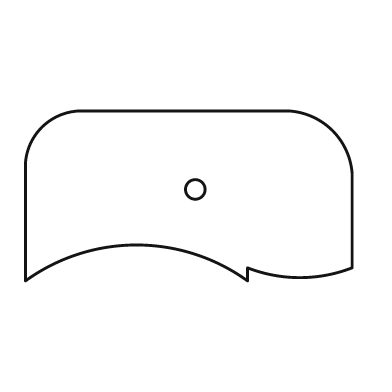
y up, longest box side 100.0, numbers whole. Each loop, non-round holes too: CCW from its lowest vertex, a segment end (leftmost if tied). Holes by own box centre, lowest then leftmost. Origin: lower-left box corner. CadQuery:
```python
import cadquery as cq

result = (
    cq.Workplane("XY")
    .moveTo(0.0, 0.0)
    .threePointArc((34.0, 11.0), (68.0, 0.0))
    .lineTo(68.0, 4.0)
    .threePointArc((84.0, 1.0), (100.0, 4.0))
    .lineTo(100.0, 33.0)
    .threePointArc((94.0, 46.0), (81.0, 52.0))
    .lineTo(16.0, 52.0)
    .threePointArc((5.0, 47.0), (0.0, 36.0))
    .close()
    .moveTo(52.0, 28.0)
    .circle(3.0)
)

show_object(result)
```